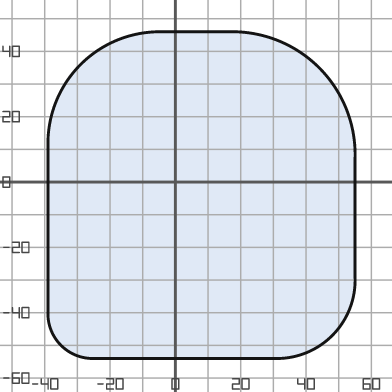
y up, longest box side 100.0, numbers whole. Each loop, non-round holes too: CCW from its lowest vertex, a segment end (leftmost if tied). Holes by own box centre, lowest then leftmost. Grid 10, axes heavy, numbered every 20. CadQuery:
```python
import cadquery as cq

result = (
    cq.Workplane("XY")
    .moveTo(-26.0, -54.0)
    .lineTo(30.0, -54.0)
    .threePointArc((48.0, -47.0), (55.0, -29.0))
    .lineTo(55.0, 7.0)
    .threePointArc((44.0, 35.0), (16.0, 46.0))
    .lineTo(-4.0, 46.0)
    .threePointArc((-29.0, 36.0), (-39.0, 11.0))
    .lineTo(-39.0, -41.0)
    .threePointArc((-35.0, -50.0), (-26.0, -54.0))
    .close()
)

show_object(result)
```